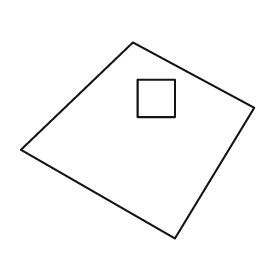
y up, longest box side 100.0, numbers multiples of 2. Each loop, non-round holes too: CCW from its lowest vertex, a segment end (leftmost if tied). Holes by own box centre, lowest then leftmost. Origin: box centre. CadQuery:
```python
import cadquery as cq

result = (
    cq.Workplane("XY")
    .moveTo(16.0, -42.0)
    .lineTo(50.0, 14.0)
    .lineTo(-2.0, 42.0)
    .lineTo(-50.0, -4.0)
    .close()
    .moveTo(0.0, 10.0)
    .lineTo(16.0, 10.0)
    .lineTo(16.0, 26.0)
    .lineTo(0.0, 26.0)
    .close()
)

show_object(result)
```